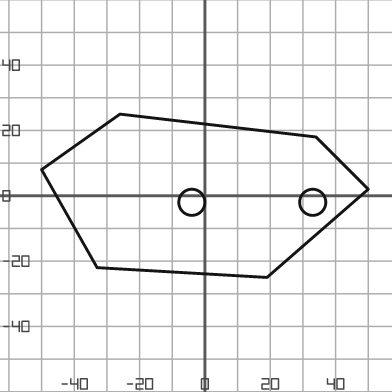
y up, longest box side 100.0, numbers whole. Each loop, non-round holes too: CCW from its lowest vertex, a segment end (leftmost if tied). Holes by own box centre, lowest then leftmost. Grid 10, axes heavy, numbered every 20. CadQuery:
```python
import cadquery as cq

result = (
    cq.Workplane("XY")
    .moveTo(19.0, -25.0)
    .lineTo(50.0, 2.0)
    .lineTo(34.0, 18.0)
    .lineTo(-26.0, 25.0)
    .lineTo(-50.0, 8.0)
    .lineTo(-33.0, -22.0)
    .close()
    .moveTo(-4.0, -2.0)
    .circle(4.0)
    .moveTo(33.0, -2.0)
    .circle(4.0)
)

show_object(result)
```